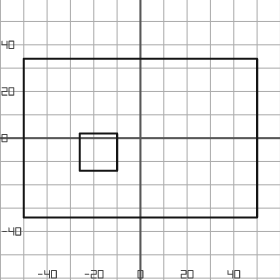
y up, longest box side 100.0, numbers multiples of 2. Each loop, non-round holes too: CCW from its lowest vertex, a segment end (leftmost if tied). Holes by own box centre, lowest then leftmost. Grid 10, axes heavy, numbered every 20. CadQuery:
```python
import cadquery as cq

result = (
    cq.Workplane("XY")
    .moveTo(-50.0, -34.0)
    .lineTo(50.0, -34.0)
    .lineTo(50.0, 34.0)
    .lineTo(-50.0, 34.0)
    .close()
    .moveTo(-26.0, -14.0)
    .lineTo(-10.0, -14.0)
    .lineTo(-10.0, 2.0)
    .lineTo(-26.0, 2.0)
    .close()
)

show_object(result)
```